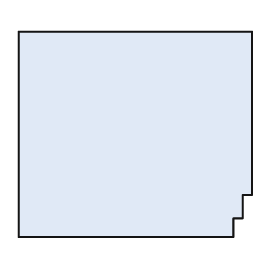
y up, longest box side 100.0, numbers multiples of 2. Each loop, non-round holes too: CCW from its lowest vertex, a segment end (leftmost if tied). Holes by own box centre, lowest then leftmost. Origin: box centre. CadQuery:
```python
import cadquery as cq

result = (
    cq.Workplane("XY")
    .moveTo(-50.0, -44.0)
    .lineTo(42.0, -44.0)
    .lineTo(42.0, -36.0)
    .lineTo(46.0, -36.0)
    .lineTo(46.0, -26.0)
    .lineTo(50.0, -26.0)
    .lineTo(50.0, 44.0)
    .lineTo(-50.0, 44.0)
    .close()
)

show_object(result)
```